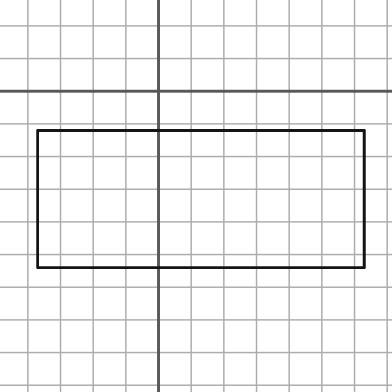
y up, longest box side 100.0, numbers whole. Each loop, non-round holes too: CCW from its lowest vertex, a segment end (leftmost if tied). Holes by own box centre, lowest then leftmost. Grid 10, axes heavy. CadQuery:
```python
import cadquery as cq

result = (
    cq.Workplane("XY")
    .moveTo(-37.0, -54.0)
    .lineTo(63.0, -54.0)
    .lineTo(63.0, -12.0)
    .lineTo(-37.0, -12.0)
    .close()
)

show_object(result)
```